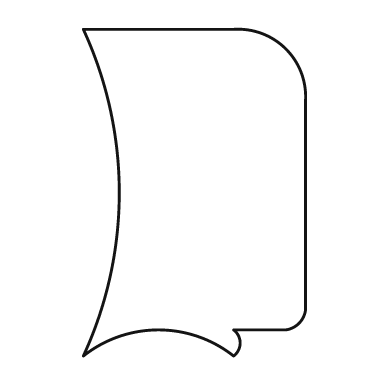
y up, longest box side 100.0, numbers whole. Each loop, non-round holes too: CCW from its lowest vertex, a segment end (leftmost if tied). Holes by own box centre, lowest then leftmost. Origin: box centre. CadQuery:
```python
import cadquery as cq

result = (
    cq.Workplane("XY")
    .moveTo(-34.0, -50.0)
    .threePointArc((-11.0, -42.0), (12.0, -50.0))
    .threePointArc((14.0, -46.0), (12.0, -42.0))
    .lineTo(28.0, -42.0)
    .threePointArc((32.0, -40.0), (34.0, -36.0))
    .lineTo(34.0, 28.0)
    .threePointArc((28.0, 44.0), (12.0, 50.0))
    .lineTo(-34.0, 50.0)
    .threePointArc((-23.0, 0.0), (-34.0, -50.0))
    .close()
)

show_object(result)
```